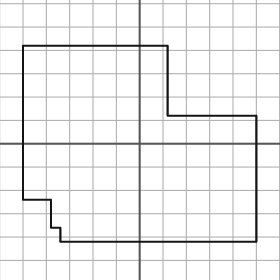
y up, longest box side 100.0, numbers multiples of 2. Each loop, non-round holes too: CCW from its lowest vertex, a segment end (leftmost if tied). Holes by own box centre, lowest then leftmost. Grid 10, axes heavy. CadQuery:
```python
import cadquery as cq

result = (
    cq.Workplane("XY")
    .moveTo(-34.0, -42.0)
    .lineTo(50.0, -42.0)
    .lineTo(50.0, 12.0)
    .lineTo(12.0, 12.0)
    .lineTo(12.0, 42.0)
    .lineTo(-50.0, 42.0)
    .lineTo(-50.0, -24.0)
    .lineTo(-38.0, -24.0)
    .lineTo(-38.0, -36.0)
    .lineTo(-34.0, -36.0)
    .close()
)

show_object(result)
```